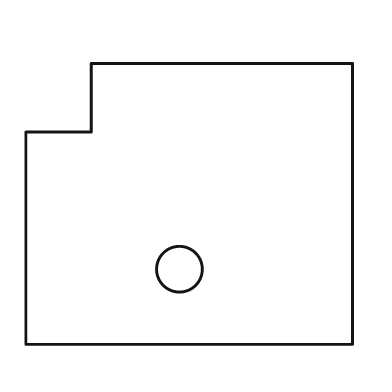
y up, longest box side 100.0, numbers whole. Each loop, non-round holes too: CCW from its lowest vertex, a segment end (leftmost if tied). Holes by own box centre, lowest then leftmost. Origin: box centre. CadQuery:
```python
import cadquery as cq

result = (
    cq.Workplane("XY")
    .moveTo(-50.0, -43.0)
    .lineTo(50.0, -43.0)
    .lineTo(50.0, 43.0)
    .lineTo(-30.0, 43.0)
    .lineTo(-30.0, 22.0)
    .lineTo(-50.0, 22.0)
    .close()
    .moveTo(-3.0, -20.0)
    .circle(7.0)
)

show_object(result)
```